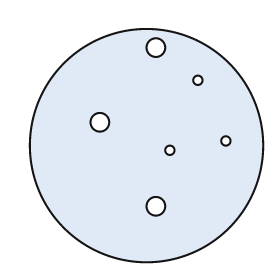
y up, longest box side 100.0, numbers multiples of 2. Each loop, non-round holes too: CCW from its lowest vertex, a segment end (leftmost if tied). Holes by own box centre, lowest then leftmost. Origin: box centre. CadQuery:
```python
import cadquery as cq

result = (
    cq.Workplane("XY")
    .moveTo(0.0, 0.0)
    .circle(50.0)
    .moveTo(4.0, -26.0)
    .circle(4.0)
    .moveTo(10.0, -2.0)
    .circle(2.0)
    .moveTo(34.0, 2.0)
    .circle(2.0)
    .moveTo(-20.0, 10.0)
    .circle(4.0)
    .moveTo(22.0, 28.0)
    .circle(2.0)
    .moveTo(4.0, 42.0)
    .circle(4.0)
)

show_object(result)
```